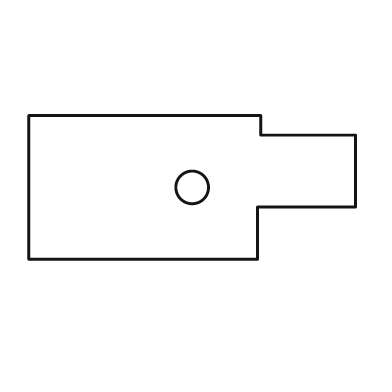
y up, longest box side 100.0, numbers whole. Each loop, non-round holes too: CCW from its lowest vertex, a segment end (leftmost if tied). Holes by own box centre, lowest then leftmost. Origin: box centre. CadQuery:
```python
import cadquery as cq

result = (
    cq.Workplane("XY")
    .moveTo(-50.0, -22.0)
    .lineTo(20.0, -22.0)
    .lineTo(20.0, -6.0)
    .lineTo(50.0, -6.0)
    .lineTo(50.0, 16.0)
    .lineTo(21.0, 16.0)
    .lineTo(21.0, 22.0)
    .lineTo(-50.0, 22.0)
    .close()
    .moveTo(0.0, 0.0)
    .circle(5.0)
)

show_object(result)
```